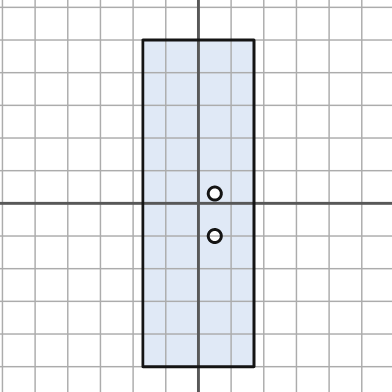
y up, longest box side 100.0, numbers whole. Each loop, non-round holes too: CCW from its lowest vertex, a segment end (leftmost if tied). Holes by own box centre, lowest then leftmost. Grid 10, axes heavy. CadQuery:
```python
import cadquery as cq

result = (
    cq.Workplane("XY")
    .moveTo(-17.0, -50.0)
    .lineTo(17.0, -50.0)
    .lineTo(17.0, 50.0)
    .lineTo(-17.0, 50.0)
    .close()
    .moveTo(5.0, -10.0)
    .circle(2.0)
    .moveTo(5.0, 3.0)
    .circle(2.0)
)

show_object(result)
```